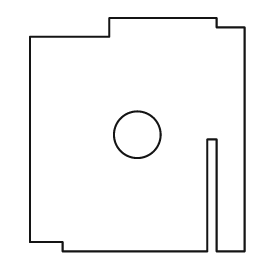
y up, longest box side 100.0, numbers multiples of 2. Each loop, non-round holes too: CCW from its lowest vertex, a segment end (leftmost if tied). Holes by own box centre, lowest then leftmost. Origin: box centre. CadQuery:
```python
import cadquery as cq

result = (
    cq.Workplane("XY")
    .moveTo(-32.0, -50.0)
    .lineTo(30.0, -50.0)
    .lineTo(30.0, -2.0)
    .lineTo(34.0, -2.0)
    .lineTo(34.0, -50.0)
    .lineTo(46.0, -50.0)
    .lineTo(46.0, 46.0)
    .lineTo(34.0, 46.0)
    .lineTo(34.0, 50.0)
    .lineTo(-12.0, 50.0)
    .lineTo(-12.0, 42.0)
    .lineTo(-46.0, 42.0)
    .lineTo(-46.0, -46.0)
    .lineTo(-32.0, -46.0)
    .close()
    .moveTo(0.0, 0.0)
    .circle(10.0)
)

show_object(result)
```